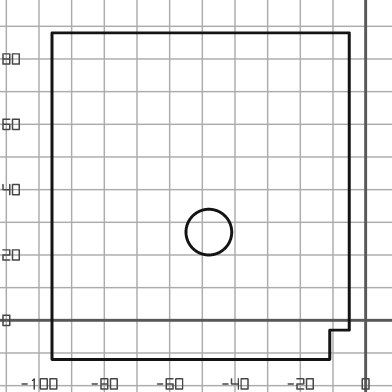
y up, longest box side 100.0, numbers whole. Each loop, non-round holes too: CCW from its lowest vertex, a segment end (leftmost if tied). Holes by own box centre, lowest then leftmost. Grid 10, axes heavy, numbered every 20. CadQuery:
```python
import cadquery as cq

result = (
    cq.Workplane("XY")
    .moveTo(-96.0, -12.0)
    .lineTo(-11.0, -12.0)
    .lineTo(-11.0, -3.0)
    .lineTo(-5.0, -3.0)
    .lineTo(-5.0, 88.0)
    .lineTo(-96.0, 88.0)
    .close()
    .moveTo(-48.0, 27.0)
    .circle(7.0)
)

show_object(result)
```